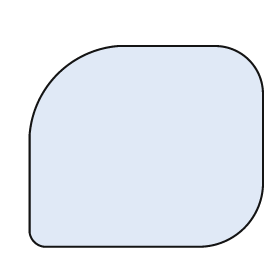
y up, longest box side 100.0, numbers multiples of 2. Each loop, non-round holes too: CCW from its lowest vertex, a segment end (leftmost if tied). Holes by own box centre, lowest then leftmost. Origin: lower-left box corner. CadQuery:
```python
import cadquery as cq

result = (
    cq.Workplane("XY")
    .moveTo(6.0, 0.0)
    .lineTo(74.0, 0.0)
    .threePointArc((92.0, 8.0), (100.0, 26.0))
    .lineTo(100.0, 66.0)
    .threePointArc((94.0, 80.0), (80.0, 86.0))
    .lineTo(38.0, 86.0)
    .threePointArc((12.0, 74.0), (0.0, 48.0))
    .lineTo(0.0, 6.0)
    .threePointArc((2.0, 2.0), (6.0, 0.0))
    .close()
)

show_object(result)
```